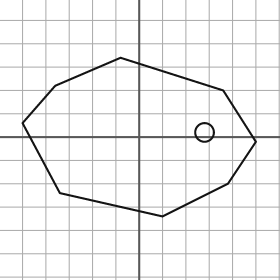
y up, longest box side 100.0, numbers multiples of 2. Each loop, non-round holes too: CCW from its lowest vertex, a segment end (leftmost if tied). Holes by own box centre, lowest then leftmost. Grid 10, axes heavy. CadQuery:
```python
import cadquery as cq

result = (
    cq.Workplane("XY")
    .moveTo(10.0, -34.0)
    .lineTo(38.0, -20.0)
    .lineTo(50.0, -2.0)
    .lineTo(36.0, 20.0)
    .lineTo(-8.0, 34.0)
    .lineTo(-36.0, 22.0)
    .lineTo(-50.0, 6.0)
    .lineTo(-34.0, -24.0)
    .close()
    .moveTo(28.0, 2.0)
    .circle(4.0)
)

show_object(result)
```